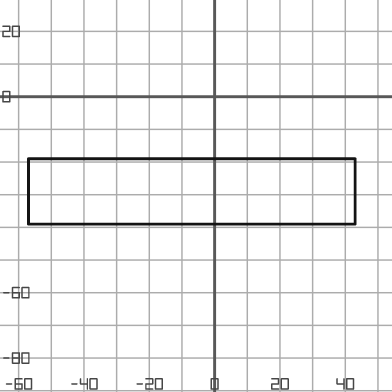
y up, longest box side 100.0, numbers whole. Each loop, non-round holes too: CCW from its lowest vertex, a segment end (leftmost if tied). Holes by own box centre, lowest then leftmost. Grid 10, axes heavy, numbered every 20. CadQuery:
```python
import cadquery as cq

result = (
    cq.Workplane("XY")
    .moveTo(-57.0, -39.0)
    .lineTo(43.0, -39.0)
    .lineTo(43.0, -19.0)
    .lineTo(-57.0, -19.0)
    .close()
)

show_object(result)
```